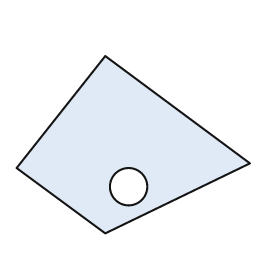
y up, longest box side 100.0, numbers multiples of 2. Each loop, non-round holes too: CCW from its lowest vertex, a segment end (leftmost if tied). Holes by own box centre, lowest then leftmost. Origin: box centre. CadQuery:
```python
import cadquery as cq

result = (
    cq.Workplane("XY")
    .moveTo(-12.0, -38.0)
    .lineTo(50.0, -8.0)
    .lineTo(-12.0, 38.0)
    .lineTo(-50.0, -10.0)
    .close()
    .moveTo(-2.0, -18.0)
    .circle(8.0)
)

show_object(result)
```